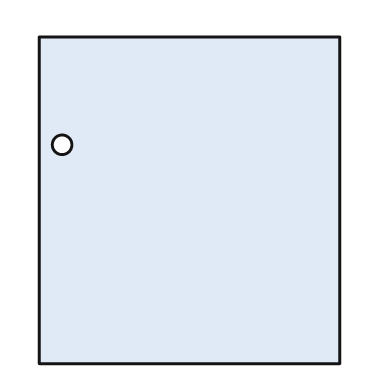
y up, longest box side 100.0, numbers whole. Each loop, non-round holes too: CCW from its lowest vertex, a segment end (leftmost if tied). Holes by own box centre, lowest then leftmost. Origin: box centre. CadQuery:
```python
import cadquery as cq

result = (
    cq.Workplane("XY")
    .moveTo(-46.0, -50.0)
    .lineTo(46.0, -50.0)
    .lineTo(46.0, 50.0)
    .lineTo(-46.0, 50.0)
    .close()
    .moveTo(-39.0, 17.0)
    .circle(3.0)
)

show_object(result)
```